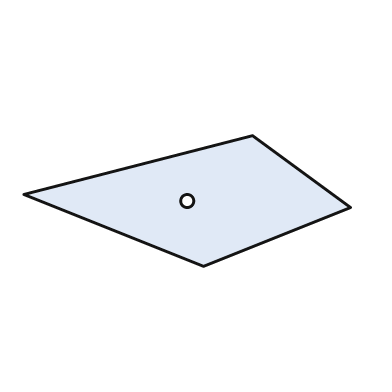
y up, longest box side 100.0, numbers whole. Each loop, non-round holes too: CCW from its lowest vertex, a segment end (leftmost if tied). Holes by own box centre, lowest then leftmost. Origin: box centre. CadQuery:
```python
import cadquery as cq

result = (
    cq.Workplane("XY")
    .moveTo(5.0, -20.0)
    .lineTo(50.0, -2.0)
    .lineTo(20.0, 20.0)
    .lineTo(-50.0, 2.0)
    .close()
    .moveTo(0.0, 0.0)
    .circle(2.0)
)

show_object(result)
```